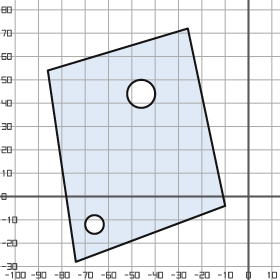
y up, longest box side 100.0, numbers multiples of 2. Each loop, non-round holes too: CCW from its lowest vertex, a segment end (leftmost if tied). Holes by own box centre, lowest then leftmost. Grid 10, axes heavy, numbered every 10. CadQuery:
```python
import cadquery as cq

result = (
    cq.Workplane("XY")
    .moveTo(-74.0, -28.0)
    .lineTo(-10.0, -4.0)
    .lineTo(-26.0, 72.0)
    .lineTo(-86.0, 54.0)
    .close()
    .moveTo(-66.0, -12.0)
    .circle(4.0)
    .moveTo(-46.0, 44.0)
    .circle(6.0)
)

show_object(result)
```